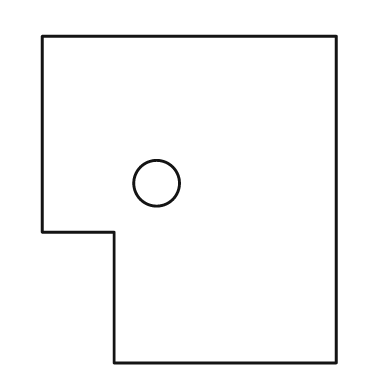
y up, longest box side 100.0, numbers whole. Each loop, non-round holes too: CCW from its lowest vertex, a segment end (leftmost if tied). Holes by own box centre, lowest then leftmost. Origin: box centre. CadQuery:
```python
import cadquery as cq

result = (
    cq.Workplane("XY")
    .moveTo(-23.0, -50.0)
    .lineTo(45.0, -50.0)
    .lineTo(45.0, 50.0)
    .lineTo(-45.0, 50.0)
    .lineTo(-45.0, -10.0)
    .lineTo(-23.0, -10.0)
    .close()
    .moveTo(-10.0, 5.0)
    .circle(7.0)
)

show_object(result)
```